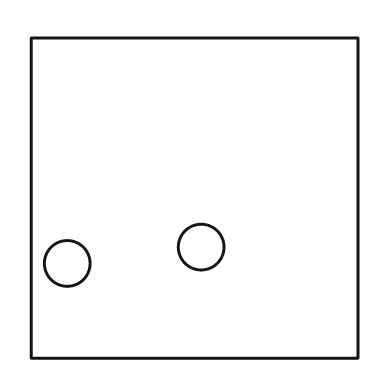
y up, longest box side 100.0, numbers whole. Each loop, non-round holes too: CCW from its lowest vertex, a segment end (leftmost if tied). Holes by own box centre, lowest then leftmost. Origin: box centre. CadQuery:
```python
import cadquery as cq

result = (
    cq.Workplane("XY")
    .moveTo(-50.0, -49.0)
    .lineTo(50.0, -49.0)
    .lineTo(50.0, 49.0)
    .lineTo(-50.0, 49.0)
    .close()
    .moveTo(-39.0, -20.0)
    .circle(7.0)
    .moveTo(2.0, -15.0)
    .circle(7.0)
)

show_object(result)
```